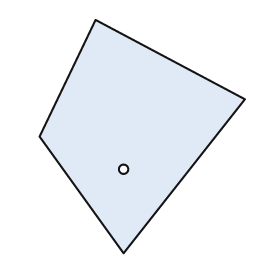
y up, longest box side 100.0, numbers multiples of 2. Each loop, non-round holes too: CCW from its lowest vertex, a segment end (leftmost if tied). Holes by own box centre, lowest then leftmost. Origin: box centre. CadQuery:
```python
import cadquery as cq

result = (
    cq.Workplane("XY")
    .moveTo(-8.0, -50.0)
    .lineTo(44.0, 16.0)
    .lineTo(-20.0, 50.0)
    .lineTo(-44.0, 0.0)
    .close()
    .moveTo(-8.0, -14.0)
    .circle(2.0)
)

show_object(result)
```